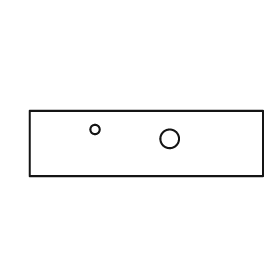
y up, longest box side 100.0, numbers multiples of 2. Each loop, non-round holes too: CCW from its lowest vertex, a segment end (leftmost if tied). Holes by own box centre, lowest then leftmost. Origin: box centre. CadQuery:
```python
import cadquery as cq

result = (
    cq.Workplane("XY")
    .moveTo(-50.0, -14.0)
    .lineTo(50.0, -14.0)
    .lineTo(50.0, 14.0)
    .lineTo(-50.0, 14.0)
    .close()
    .moveTo(10.0, 2.0)
    .circle(4.0)
    .moveTo(-22.0, 6.0)
    .circle(2.0)
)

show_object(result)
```